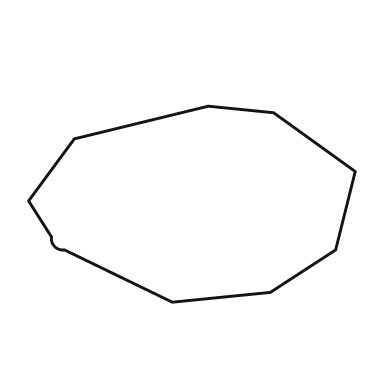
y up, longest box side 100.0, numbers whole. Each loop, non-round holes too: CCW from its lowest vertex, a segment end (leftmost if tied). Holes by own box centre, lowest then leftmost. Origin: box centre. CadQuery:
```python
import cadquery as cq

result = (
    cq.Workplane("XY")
    .moveTo(-6.0, -30.0)
    .lineTo(24.0, -27.0)
    .lineTo(44.0, -14.0)
    .lineTo(50.0, 10.0)
    .lineTo(25.0, 28.0)
    .lineTo(5.0, 30.0)
    .lineTo(-36.0, 20.0)
    .lineTo(-50.0, 1.0)
    .lineTo(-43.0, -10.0)
    .threePointArc((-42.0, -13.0), (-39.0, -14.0))
    .close()
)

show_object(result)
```